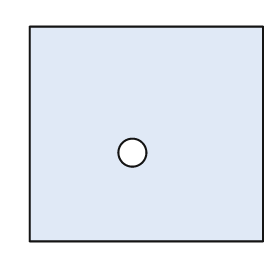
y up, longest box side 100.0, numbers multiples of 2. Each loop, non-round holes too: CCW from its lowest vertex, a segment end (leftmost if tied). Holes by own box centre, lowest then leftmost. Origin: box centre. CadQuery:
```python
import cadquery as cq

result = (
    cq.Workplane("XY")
    .moveTo(-50.0, -46.0)
    .lineTo(50.0, -46.0)
    .lineTo(50.0, 46.0)
    .lineTo(-50.0, 46.0)
    .close()
    .moveTo(-6.0, -8.0)
    .circle(6.0)
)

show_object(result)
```